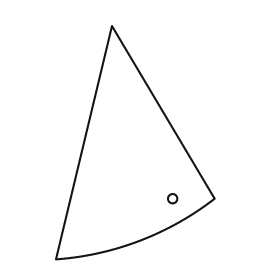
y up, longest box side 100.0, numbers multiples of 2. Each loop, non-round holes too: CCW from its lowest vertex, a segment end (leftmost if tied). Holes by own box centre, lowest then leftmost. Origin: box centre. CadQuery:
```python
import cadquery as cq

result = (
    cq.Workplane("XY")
    .moveTo(-34.0, -50.0)
    .threePointArc((2.0, -42.0), (34.0, -24.0))
    .lineTo(-10.0, 50.0)
    .close()
    .moveTo(16.0, -24.0)
    .circle(2.0)
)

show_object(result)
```